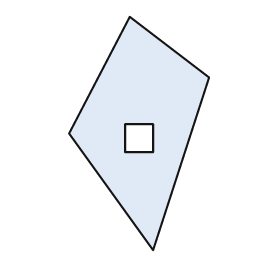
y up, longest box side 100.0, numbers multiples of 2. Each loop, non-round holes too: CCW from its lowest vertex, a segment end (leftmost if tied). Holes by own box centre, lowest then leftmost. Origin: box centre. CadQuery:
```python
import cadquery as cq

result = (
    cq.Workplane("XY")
    .moveTo(6.0, -50.0)
    .lineTo(30.0, 24.0)
    .lineTo(-4.0, 50.0)
    .lineTo(-30.0, 0.0)
    .close()
    .moveTo(-6.0, -8.0)
    .lineTo(6.0, -8.0)
    .lineTo(6.0, 4.0)
    .lineTo(-6.0, 4.0)
    .close()
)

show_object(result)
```